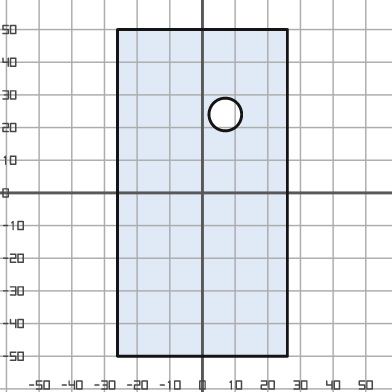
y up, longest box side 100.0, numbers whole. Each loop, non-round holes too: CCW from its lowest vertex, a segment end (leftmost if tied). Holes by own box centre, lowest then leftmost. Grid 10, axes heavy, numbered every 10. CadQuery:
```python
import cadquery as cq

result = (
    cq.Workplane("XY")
    .moveTo(-26.0, -50.0)
    .lineTo(26.0, -50.0)
    .lineTo(26.0, 50.0)
    .lineTo(-26.0, 50.0)
    .close()
    .moveTo(7.0, 24.0)
    .circle(5.0)
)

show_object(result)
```